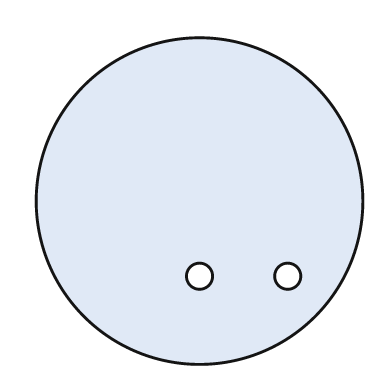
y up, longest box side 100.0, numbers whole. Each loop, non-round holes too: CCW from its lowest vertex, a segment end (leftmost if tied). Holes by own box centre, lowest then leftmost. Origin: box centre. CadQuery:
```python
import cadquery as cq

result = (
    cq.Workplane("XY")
    .moveTo(0.0, 0.0)
    .circle(50.0)
    .moveTo(0.0, -23.0)
    .circle(4.0)
    .moveTo(27.0, -23.0)
    .circle(4.0)
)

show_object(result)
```